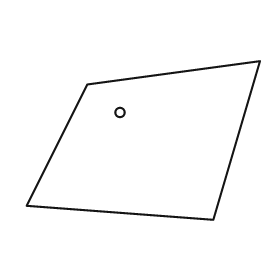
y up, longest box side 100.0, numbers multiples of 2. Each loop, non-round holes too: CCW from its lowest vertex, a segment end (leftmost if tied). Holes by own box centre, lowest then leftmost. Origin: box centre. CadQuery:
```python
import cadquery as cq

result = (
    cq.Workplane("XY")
    .moveTo(30.0, -34.0)
    .lineTo(50.0, 34.0)
    .lineTo(-24.0, 24.0)
    .lineTo(-50.0, -28.0)
    .close()
    .moveTo(-10.0, 12.0)
    .circle(2.0)
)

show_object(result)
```